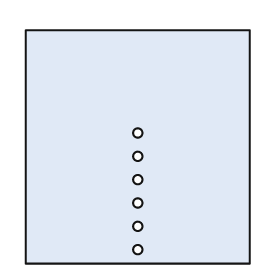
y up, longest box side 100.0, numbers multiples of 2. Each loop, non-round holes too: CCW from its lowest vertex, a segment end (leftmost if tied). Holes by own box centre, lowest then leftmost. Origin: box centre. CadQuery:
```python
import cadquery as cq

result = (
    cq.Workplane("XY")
    .moveTo(-48.0, -50.0)
    .lineTo(48.0, -50.0)
    .lineTo(48.0, 50.0)
    .lineTo(-48.0, 50.0)
    .close()
    .moveTo(0.0, -44.0)
    .circle(2.0)
    .moveTo(0.0, -34.0)
    .circle(2.0)
    .moveTo(0.0, -24.0)
    .circle(2.0)
    .moveTo(0.0, -14.0)
    .circle(2.0)
    .moveTo(0.0, -4.0)
    .circle(2.0)
    .moveTo(0.0, 6.0)
    .circle(2.0)
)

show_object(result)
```